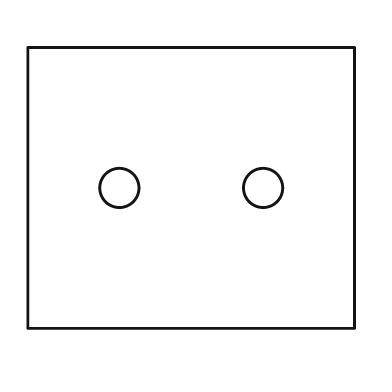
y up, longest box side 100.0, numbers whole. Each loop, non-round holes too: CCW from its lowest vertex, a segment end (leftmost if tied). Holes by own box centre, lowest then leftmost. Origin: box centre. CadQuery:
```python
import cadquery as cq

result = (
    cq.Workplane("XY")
    .moveTo(-50.0, -43.0)
    .lineTo(50.0, -43.0)
    .lineTo(50.0, 43.0)
    .lineTo(-50.0, 43.0)
    .close()
    .moveTo(-22.0, 0.0)
    .circle(6.0)
    .moveTo(22.0, 0.0)
    .circle(6.0)
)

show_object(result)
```